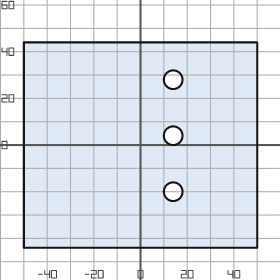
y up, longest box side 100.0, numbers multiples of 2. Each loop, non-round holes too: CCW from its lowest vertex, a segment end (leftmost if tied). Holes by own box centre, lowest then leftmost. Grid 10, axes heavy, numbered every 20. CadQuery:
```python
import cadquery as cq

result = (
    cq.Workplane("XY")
    .moveTo(-50.0, -44.0)
    .lineTo(50.0, -44.0)
    .lineTo(50.0, 44.0)
    .lineTo(-50.0, 44.0)
    .close()
    .moveTo(14.0, -20.0)
    .circle(4.0)
    .moveTo(14.0, 4.0)
    .circle(4.0)
    .moveTo(14.0, 28.0)
    .circle(4.0)
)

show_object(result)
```